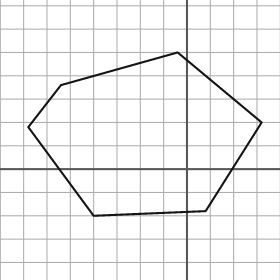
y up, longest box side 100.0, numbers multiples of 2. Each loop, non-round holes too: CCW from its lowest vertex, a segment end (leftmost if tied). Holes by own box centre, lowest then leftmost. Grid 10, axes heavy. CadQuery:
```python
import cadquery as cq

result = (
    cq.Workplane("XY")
    .moveTo(-40.0, -20.0)
    .lineTo(8.0, -18.0)
    .lineTo(32.0, 20.0)
    .lineTo(-4.0, 50.0)
    .lineTo(-54.0, 36.0)
    .lineTo(-68.0, 18.0)
    .close()
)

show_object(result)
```